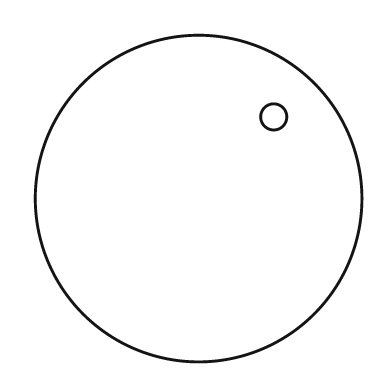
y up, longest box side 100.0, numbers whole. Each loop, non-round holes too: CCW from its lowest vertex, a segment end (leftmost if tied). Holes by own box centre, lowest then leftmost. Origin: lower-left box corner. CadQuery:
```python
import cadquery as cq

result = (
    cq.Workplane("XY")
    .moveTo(50.0, 50.0)
    .circle(50.0)
    .moveTo(73.0, 75.0)
    .circle(4.0)
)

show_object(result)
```